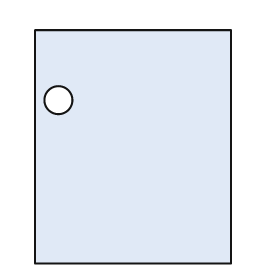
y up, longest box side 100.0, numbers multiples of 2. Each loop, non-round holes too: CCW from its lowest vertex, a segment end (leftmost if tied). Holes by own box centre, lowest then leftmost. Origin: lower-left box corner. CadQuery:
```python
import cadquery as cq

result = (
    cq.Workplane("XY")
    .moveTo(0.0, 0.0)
    .lineTo(84.0, 0.0)
    .lineTo(84.0, 100.0)
    .lineTo(0.0, 100.0)
    .close()
    .moveTo(10.0, 70.0)
    .circle(6.0)
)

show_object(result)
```